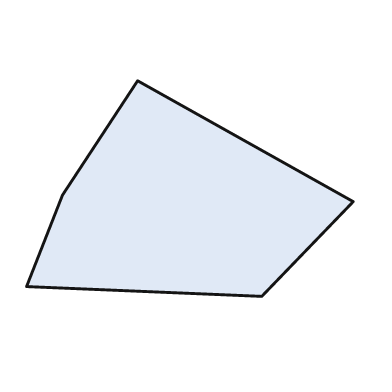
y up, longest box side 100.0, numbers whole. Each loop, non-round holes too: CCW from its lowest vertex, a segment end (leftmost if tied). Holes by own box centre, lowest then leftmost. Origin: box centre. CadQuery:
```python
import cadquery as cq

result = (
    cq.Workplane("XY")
    .moveTo(22.0, -33.0)
    .lineTo(50.0, -4.0)
    .lineTo(-16.0, 33.0)
    .lineTo(-39.0, -2.0)
    .lineTo(-50.0, -30.0)
    .close()
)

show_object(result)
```